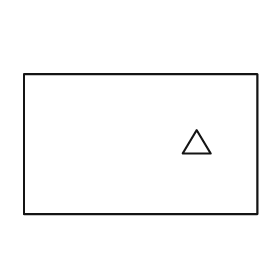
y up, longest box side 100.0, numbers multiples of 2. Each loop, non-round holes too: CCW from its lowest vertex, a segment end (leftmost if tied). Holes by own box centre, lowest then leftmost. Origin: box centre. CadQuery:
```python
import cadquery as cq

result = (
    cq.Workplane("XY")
    .moveTo(-50.0, -30.0)
    .lineTo(50.0, -30.0)
    .lineTo(50.0, 30.0)
    .lineTo(-50.0, 30.0)
    .close()
    .moveTo(18.0, -4.0)
    .lineTo(30.0, -4.0)
    .lineTo(24.0, 6.0)
    .close()
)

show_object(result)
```